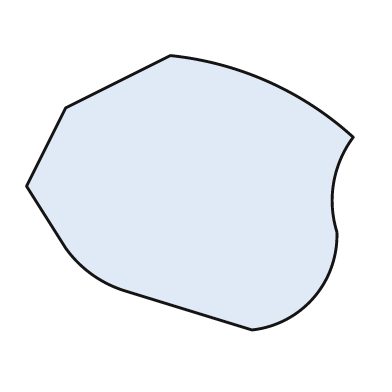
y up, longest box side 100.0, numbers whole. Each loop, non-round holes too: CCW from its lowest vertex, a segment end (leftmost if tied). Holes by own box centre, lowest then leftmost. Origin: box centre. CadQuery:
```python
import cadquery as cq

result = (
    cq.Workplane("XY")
    .moveTo(19.0, -42.0)
    .threePointArc((38.0, -32.0), (45.0, -12.0))
    .threePointArc((44.0, 3.0), (50.0, 17.0))
    .threePointArc((24.0, 34.0), (-6.0, 42.0))
    .lineTo(-38.0, 26.0)
    .lineTo(-50.0, 2.0)
    .lineTo(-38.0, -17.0)
    .threePointArc((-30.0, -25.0), (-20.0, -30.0))
    .close()
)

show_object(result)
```